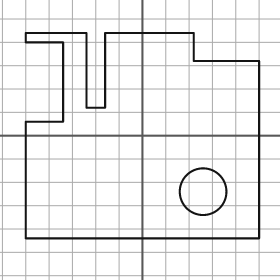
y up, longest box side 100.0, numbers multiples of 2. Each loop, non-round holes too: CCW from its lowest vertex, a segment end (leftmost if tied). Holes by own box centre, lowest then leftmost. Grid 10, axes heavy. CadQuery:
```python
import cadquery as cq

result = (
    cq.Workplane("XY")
    .moveTo(-50.0, -44.0)
    .lineTo(50.0, -44.0)
    .lineTo(50.0, 32.0)
    .lineTo(22.0, 32.0)
    .lineTo(22.0, 44.0)
    .lineTo(-16.0, 44.0)
    .lineTo(-16.0, 12.0)
    .lineTo(-24.0, 12.0)
    .lineTo(-24.0, 44.0)
    .lineTo(-50.0, 44.0)
    .lineTo(-50.0, 40.0)
    .lineTo(-34.0, 40.0)
    .lineTo(-34.0, 6.0)
    .lineTo(-50.0, 6.0)
    .close()
    .moveTo(26.0, -24.0)
    .circle(10.0)
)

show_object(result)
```